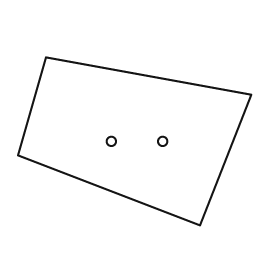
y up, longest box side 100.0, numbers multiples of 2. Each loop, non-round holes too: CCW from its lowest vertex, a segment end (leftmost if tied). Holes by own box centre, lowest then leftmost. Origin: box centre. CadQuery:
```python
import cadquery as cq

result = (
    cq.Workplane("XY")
    .moveTo(28.0, -36.0)
    .lineTo(50.0, 20.0)
    .lineTo(-38.0, 36.0)
    .lineTo(-50.0, -6.0)
    .close()
    .moveTo(-10.0, 0.0)
    .circle(2.0)
    .moveTo(12.0, 0.0)
    .circle(2.0)
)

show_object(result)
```